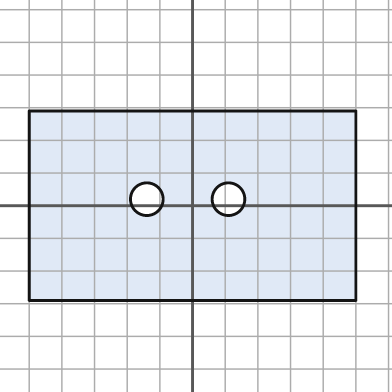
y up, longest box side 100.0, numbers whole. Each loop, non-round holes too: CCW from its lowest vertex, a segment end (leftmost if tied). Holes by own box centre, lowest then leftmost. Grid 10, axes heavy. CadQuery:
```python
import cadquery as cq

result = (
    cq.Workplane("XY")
    .moveTo(-50.0, -29.0)
    .lineTo(50.0, -29.0)
    .lineTo(50.0, 29.0)
    .lineTo(-50.0, 29.0)
    .close()
    .moveTo(-14.0, 2.0)
    .circle(5.0)
    .moveTo(11.0, 2.0)
    .circle(5.0)
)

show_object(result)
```